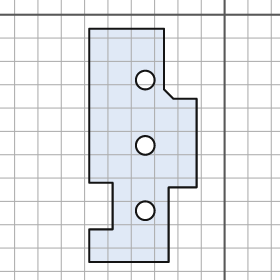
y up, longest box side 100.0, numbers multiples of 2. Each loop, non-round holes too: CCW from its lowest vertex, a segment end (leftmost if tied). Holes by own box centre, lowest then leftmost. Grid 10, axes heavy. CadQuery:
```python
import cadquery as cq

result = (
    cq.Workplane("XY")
    .moveTo(-58.0, -106.0)
    .lineTo(-24.0, -106.0)
    .lineTo(-24.0, -74.0)
    .lineTo(-12.0, -74.0)
    .lineTo(-12.0, -36.0)
    .lineTo(-22.0, -36.0)
    .lineTo(-26.0, -32.0)
    .lineTo(-26.0, -6.0)
    .lineTo(-58.0, -6.0)
    .lineTo(-58.0, -72.0)
    .lineTo(-48.0, -72.0)
    .lineTo(-48.0, -92.0)
    .lineTo(-58.0, -92.0)
    .close()
    .moveTo(-34.0, -84.0)
    .circle(4.0)
    .moveTo(-34.0, -56.0)
    .circle(4.0)
    .moveTo(-34.0, -28.0)
    .circle(4.0)
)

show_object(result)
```